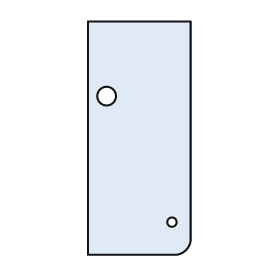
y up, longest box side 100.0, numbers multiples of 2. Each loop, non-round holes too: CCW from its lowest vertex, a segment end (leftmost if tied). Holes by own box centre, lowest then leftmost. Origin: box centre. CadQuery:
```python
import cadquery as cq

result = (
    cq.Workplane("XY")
    .moveTo(-22.0, -50.0)
    .lineTo(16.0, -50.0)
    .threePointArc((20.0, -48.0), (22.0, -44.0))
    .lineTo(22.0, 50.0)
    .lineTo(-22.0, 50.0)
    .close()
    .moveTo(14.0, -36.0)
    .circle(2.0)
    .moveTo(-14.0, 18.0)
    .circle(4.0)
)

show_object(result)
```